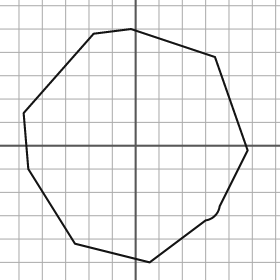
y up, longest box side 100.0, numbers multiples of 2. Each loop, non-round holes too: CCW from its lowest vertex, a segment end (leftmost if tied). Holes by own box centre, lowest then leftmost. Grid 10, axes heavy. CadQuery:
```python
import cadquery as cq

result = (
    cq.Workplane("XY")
    .moveTo(6.0, -50.0)
    .lineTo(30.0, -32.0)
    .threePointArc((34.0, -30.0), (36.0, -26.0))
    .lineTo(48.0, -2.0)
    .lineTo(34.0, 38.0)
    .lineTo(-2.0, 50.0)
    .lineTo(-18.0, 48.0)
    .lineTo(-48.0, 14.0)
    .lineTo(-46.0, -10.0)
    .lineTo(-26.0, -42.0)
    .close()
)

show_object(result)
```